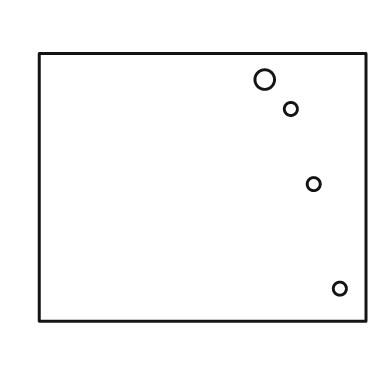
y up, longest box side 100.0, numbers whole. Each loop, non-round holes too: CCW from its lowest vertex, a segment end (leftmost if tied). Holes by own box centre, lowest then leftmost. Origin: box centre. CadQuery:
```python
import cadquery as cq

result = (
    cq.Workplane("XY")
    .moveTo(-50.0, -41.0)
    .lineTo(50.0, -41.0)
    .lineTo(50.0, 41.0)
    .lineTo(-50.0, 41.0)
    .close()
    .moveTo(42.0, -31.0)
    .circle(2.0)
    .moveTo(34.0, 1.0)
    .circle(2.0)
    .moveTo(27.0, 24.0)
    .circle(2.0)
    .moveTo(19.0, 33.0)
    .circle(3.0)
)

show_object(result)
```